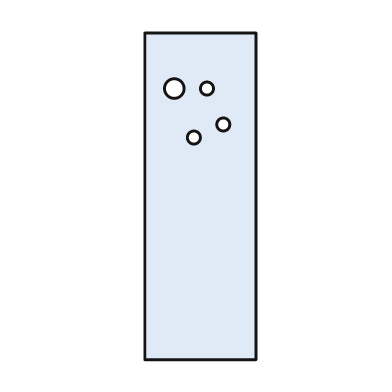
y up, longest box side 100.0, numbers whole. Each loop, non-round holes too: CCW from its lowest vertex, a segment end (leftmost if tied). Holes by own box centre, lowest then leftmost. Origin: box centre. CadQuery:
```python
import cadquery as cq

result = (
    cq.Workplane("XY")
    .moveTo(-17.0, -50.0)
    .lineTo(17.0, -50.0)
    .lineTo(17.0, 50.0)
    .lineTo(-17.0, 50.0)
    .close()
    .moveTo(-2.0, 18.0)
    .circle(2.0)
    .moveTo(7.0, 22.0)
    .circle(2.0)
    .moveTo(-8.0, 33.0)
    .circle(3.0)
    .moveTo(2.0, 33.0)
    .circle(2.0)
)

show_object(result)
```